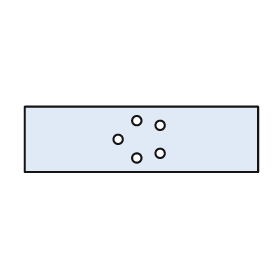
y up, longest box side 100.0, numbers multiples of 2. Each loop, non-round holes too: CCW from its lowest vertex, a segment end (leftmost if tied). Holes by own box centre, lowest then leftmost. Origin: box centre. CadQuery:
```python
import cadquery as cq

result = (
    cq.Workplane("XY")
    .moveTo(-50.0, -14.0)
    .lineTo(50.0, -14.0)
    .lineTo(50.0, 14.0)
    .lineTo(-50.0, 14.0)
    .close()
    .moveTo(-2.0, -8.0)
    .circle(2.0)
    .moveTo(8.0, -6.0)
    .circle(2.0)
    .moveTo(-10.0, 0.0)
    .circle(2.0)
    .moveTo(8.0, 6.0)
    .circle(2.0)
    .moveTo(-2.0, 8.0)
    .circle(2.0)
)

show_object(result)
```